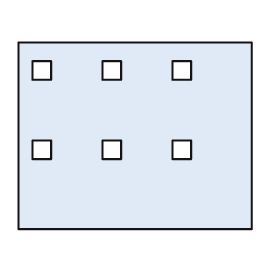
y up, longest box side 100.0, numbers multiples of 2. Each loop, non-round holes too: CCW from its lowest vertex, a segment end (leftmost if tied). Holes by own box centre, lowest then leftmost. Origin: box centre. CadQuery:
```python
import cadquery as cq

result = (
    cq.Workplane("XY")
    .moveTo(-50.0, -40.0)
    .lineTo(50.0, -40.0)
    .lineTo(50.0, 40.0)
    .lineTo(-50.0, 40.0)
    .close()
    .moveTo(-44.0, -10.0)
    .lineTo(-36.0, -10.0)
    .lineTo(-36.0, -2.0)
    .lineTo(-44.0, -2.0)
    .close()
    .moveTo(-14.0, -10.0)
    .lineTo(-6.0, -10.0)
    .lineTo(-6.0, -2.0)
    .lineTo(-14.0, -2.0)
    .close()
    .moveTo(16.0, -10.0)
    .lineTo(24.0, -10.0)
    .lineTo(24.0, -2.0)
    .lineTo(16.0, -2.0)
    .close()
    .moveTo(-44.0, 24.0)
    .lineTo(-36.0, 24.0)
    .lineTo(-36.0, 32.0)
    .lineTo(-44.0, 32.0)
    .close()
    .moveTo(-14.0, 24.0)
    .lineTo(-6.0, 24.0)
    .lineTo(-6.0, 32.0)
    .lineTo(-14.0, 32.0)
    .close()
    .moveTo(16.0, 24.0)
    .lineTo(24.0, 24.0)
    .lineTo(24.0, 32.0)
    .lineTo(16.0, 32.0)
    .close()
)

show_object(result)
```